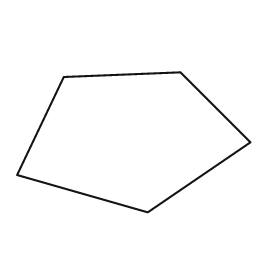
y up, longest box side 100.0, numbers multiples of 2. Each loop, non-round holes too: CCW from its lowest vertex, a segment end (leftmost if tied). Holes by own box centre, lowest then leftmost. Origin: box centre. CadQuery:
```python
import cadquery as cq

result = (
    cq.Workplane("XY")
    .moveTo(6.0, -30.0)
    .lineTo(50.0, 0.0)
    .lineTo(20.0, 30.0)
    .lineTo(-30.0, 28.0)
    .lineTo(-50.0, -14.0)
    .close()
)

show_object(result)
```